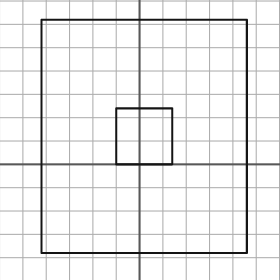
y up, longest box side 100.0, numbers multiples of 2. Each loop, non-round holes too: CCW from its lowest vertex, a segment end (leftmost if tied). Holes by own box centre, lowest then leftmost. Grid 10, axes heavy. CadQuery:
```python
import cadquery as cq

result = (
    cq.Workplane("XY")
    .moveTo(-42.0, -38.0)
    .lineTo(46.0, -38.0)
    .lineTo(46.0, 62.0)
    .lineTo(-42.0, 62.0)
    .close()
    .moveTo(-10.0, 0.0)
    .lineTo(14.0, 0.0)
    .lineTo(14.0, 24.0)
    .lineTo(-10.0, 24.0)
    .close()
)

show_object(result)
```